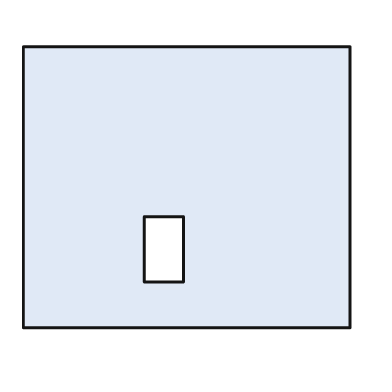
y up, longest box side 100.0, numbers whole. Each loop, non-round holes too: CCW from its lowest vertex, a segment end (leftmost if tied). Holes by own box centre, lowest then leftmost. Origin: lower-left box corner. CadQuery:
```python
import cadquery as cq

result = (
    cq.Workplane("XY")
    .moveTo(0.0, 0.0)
    .lineTo(100.0, 0.0)
    .lineTo(100.0, 86.0)
    .lineTo(0.0, 86.0)
    .close()
    .moveTo(37.0, 14.0)
    .lineTo(49.0, 14.0)
    .lineTo(49.0, 34.0)
    .lineTo(37.0, 34.0)
    .close()
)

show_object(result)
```